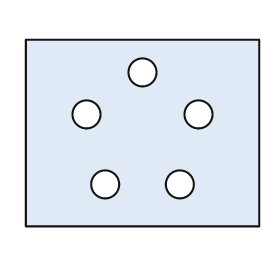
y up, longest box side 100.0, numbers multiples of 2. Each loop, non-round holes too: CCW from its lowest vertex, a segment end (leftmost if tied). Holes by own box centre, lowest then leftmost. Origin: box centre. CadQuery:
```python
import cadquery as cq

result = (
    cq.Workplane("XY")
    .moveTo(-50.0, -40.0)
    .lineTo(50.0, -40.0)
    .lineTo(50.0, 40.0)
    .lineTo(-50.0, 40.0)
    .close()
    .moveTo(-16.0, -22.0)
    .circle(6.0)
    .moveTo(16.0, -22.0)
    .circle(6.0)
    .moveTo(-24.0, 8.0)
    .circle(6.0)
    .moveTo(24.0, 8.0)
    .circle(6.0)
    .moveTo(0.0, 26.0)
    .circle(6.0)
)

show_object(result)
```